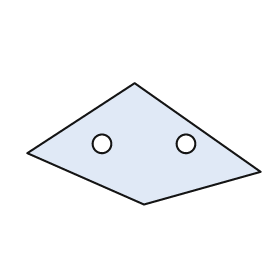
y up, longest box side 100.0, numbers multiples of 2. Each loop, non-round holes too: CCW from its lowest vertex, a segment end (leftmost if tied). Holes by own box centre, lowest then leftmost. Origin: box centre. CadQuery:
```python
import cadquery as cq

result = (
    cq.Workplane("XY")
    .moveTo(0.0, -26.0)
    .lineTo(50.0, -12.0)
    .lineTo(-4.0, 26.0)
    .lineTo(-50.0, -4.0)
    .close()
    .moveTo(-18.0, 0.0)
    .circle(4.0)
    .moveTo(18.0, 0.0)
    .circle(4.0)
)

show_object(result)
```